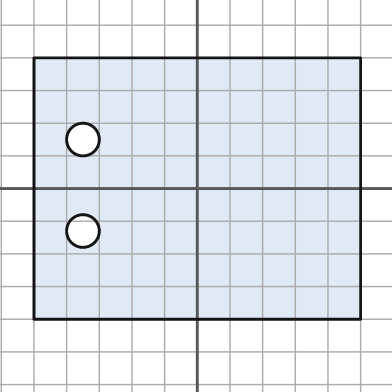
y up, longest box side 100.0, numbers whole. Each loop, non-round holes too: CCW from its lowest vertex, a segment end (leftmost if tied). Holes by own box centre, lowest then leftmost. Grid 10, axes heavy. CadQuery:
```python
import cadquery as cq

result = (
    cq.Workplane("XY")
    .moveTo(-50.0, -40.0)
    .lineTo(50.0, -40.0)
    .lineTo(50.0, 40.0)
    .lineTo(-50.0, 40.0)
    .close()
    .moveTo(-35.0, -13.0)
    .circle(5.0)
    .moveTo(-35.0, 15.0)
    .circle(5.0)
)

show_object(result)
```